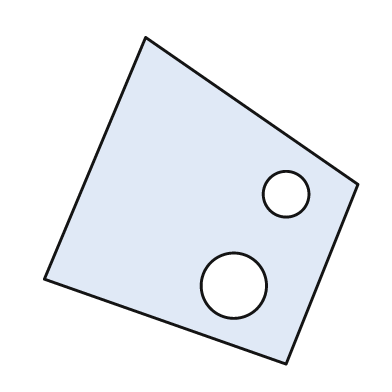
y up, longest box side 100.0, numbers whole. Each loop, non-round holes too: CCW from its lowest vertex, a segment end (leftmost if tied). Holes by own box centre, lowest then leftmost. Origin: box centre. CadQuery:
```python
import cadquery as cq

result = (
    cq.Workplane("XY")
    .moveTo(26.0, -50.0)
    .lineTo(48.0, 5.0)
    .lineTo(-17.0, 50.0)
    .lineTo(-48.0, -24.0)
    .close()
    .moveTo(10.0, -26.0)
    .circle(10.0)
    .moveTo(26.0, 2.0)
    .circle(7.0)
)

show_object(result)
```